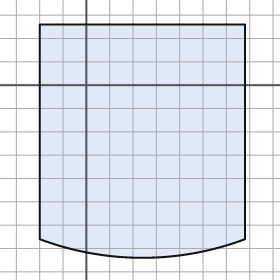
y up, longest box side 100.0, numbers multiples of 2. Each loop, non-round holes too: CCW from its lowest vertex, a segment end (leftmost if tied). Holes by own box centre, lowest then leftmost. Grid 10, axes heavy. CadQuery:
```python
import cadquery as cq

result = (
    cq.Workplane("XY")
    .moveTo(-20.0, -66.0)
    .threePointArc((24.0, -74.0), (68.0, -66.0))
    .lineTo(68.0, 26.0)
    .lineTo(-20.0, 26.0)
    .close()
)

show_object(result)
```